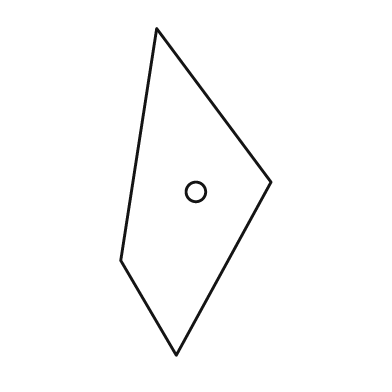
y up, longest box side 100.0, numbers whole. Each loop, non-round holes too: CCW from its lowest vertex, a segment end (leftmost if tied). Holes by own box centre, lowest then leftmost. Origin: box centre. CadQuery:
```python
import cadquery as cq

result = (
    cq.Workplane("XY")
    .moveTo(-6.0, -50.0)
    .lineTo(23.0, 3.0)
    .lineTo(-12.0, 50.0)
    .lineTo(-23.0, -21.0)
    .close()
    .moveTo(0.0, 0.0)
    .circle(3.0)
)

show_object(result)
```